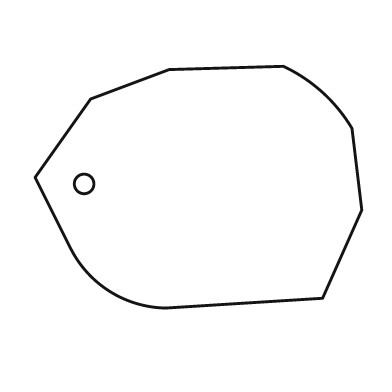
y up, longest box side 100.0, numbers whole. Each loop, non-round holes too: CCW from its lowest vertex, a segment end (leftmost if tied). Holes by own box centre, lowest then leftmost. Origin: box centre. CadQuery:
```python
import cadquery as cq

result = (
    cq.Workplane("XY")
    .moveTo(-10.0, -37.0)
    .lineTo(38.0, -34.0)
    .lineTo(50.0, -7.0)
    .lineTo(47.0, 18.0)
    .threePointArc((38.0, 29.0), (26.0, 37.0))
    .lineTo(-9.0, 36.0)
    .lineTo(-33.0, 27.0)
    .lineTo(-50.0, 3.0)
    .lineTo(-39.0, -19.0)
    .threePointArc((-27.0, -32.0), (-10.0, -37.0))
    .close()
    .moveTo(-35.0, 1.0)
    .circle(3.0)
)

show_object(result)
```